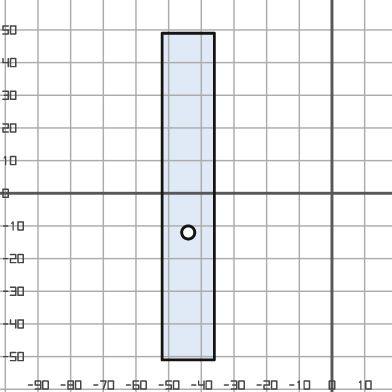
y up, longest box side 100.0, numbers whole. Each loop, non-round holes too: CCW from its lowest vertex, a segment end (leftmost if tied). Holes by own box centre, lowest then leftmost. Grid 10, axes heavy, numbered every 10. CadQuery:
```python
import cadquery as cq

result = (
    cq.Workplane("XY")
    .moveTo(-52.0, -51.0)
    .lineTo(-36.0, -51.0)
    .lineTo(-36.0, 49.0)
    .lineTo(-52.0, 49.0)
    .close()
    .moveTo(-44.0, -12.0)
    .circle(2.0)
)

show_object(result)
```